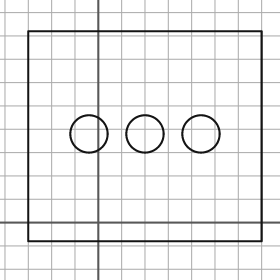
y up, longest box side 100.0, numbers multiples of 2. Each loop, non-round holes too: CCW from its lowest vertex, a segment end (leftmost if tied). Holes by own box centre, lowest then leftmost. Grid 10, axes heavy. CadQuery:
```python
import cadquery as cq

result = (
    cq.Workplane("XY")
    .moveTo(-30.0, -8.0)
    .lineTo(70.0, -8.0)
    .lineTo(70.0, 82.0)
    .lineTo(-30.0, 82.0)
    .close()
    .moveTo(-4.0, 38.0)
    .circle(8.0)
    .moveTo(20.0, 38.0)
    .circle(8.0)
    .moveTo(44.0, 38.0)
    .circle(8.0)
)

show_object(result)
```